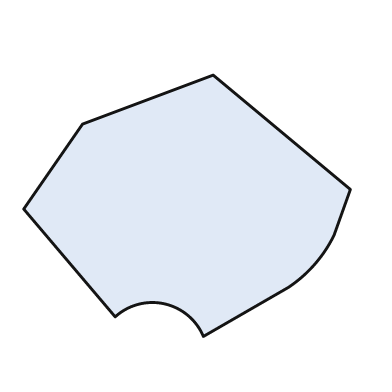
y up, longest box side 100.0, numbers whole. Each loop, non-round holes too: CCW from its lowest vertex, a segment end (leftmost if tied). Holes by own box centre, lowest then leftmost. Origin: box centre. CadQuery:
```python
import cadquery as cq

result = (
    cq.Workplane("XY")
    .moveTo(5.0, -40.0)
    .lineTo(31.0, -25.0)
    .threePointArc((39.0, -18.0), (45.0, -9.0))
    .lineTo(50.0, 5.0)
    .lineTo(8.0, 40.0)
    .lineTo(-32.0, 25.0)
    .lineTo(-50.0, -1.0)
    .lineTo(-22.0, -34.0)
    .threePointArc((-7.0, -30.0), (5.0, -40.0))
    .close()
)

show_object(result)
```